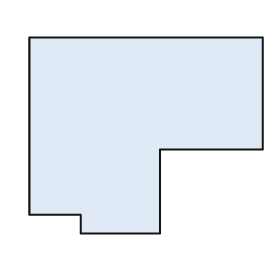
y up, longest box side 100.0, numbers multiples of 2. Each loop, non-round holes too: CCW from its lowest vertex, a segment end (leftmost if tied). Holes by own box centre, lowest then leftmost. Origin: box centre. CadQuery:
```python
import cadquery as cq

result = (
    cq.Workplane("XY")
    .moveTo(-28.0, -42.0)
    .lineTo(6.0, -42.0)
    .lineTo(6.0, -6.0)
    .lineTo(50.0, -6.0)
    .lineTo(50.0, 42.0)
    .lineTo(-50.0, 42.0)
    .lineTo(-50.0, -34.0)
    .lineTo(-28.0, -34.0)
    .close()
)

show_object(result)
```